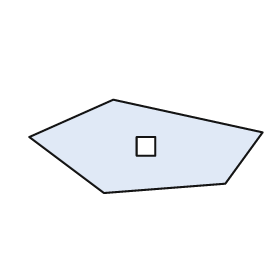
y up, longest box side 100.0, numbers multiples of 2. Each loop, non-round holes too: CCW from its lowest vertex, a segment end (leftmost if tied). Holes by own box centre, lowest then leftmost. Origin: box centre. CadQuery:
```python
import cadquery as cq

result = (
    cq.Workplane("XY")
    .moveTo(-18.0, -20.0)
    .lineTo(34.0, -16.0)
    .lineTo(50.0, 6.0)
    .lineTo(-14.0, 20.0)
    .lineTo(-50.0, 4.0)
    .close()
    .moveTo(-4.0, -4.0)
    .lineTo(4.0, -4.0)
    .lineTo(4.0, 4.0)
    .lineTo(-4.0, 4.0)
    .close()
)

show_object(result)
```